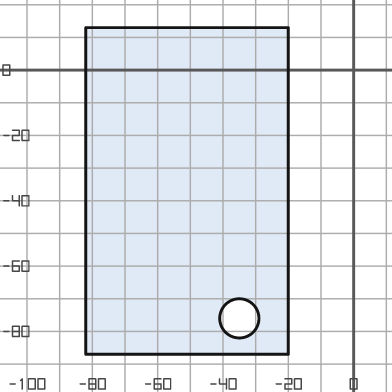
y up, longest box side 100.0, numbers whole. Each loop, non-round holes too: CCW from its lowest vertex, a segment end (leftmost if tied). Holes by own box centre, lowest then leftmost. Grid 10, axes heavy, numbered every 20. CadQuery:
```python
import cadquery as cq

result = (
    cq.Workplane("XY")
    .moveTo(-82.0, -87.0)
    .lineTo(-20.0, -87.0)
    .lineTo(-20.0, 13.0)
    .lineTo(-82.0, 13.0)
    .close()
    .moveTo(-35.0, -76.0)
    .circle(6.0)
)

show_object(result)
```